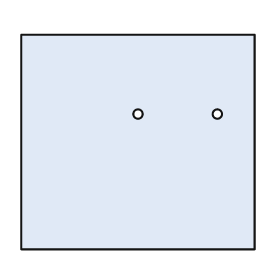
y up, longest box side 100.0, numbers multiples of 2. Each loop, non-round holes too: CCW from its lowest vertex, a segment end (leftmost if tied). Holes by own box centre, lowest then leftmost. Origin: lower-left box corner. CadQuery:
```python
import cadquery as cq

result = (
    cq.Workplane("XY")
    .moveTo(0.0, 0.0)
    .lineTo(100.0, 0.0)
    .lineTo(100.0, 92.0)
    .lineTo(0.0, 92.0)
    .close()
    .moveTo(50.0, 58.0)
    .circle(2.0)
    .moveTo(84.0, 58.0)
    .circle(2.0)
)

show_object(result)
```